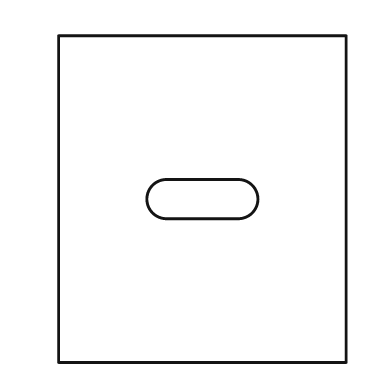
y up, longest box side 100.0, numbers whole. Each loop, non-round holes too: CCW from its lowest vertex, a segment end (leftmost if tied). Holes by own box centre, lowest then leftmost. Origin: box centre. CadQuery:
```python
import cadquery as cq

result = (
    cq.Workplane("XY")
    .moveTo(-44.0, -50.0)
    .lineTo(44.0, -50.0)
    .lineTo(44.0, 50.0)
    .lineTo(-44.0, 50.0)
    .close()
    .moveTo(-11.0, -6.0)
    .lineTo(11.0, -6.0)
    .threePointArc((17.0, 0.0), (11.0, 6.0))
    .lineTo(-11.0, 6.0)
    .threePointArc((-17.0, 0.0), (-11.0, -6.0))
    .close()
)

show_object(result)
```